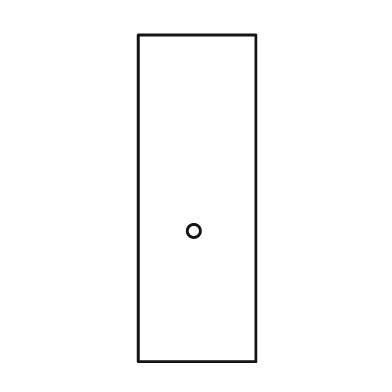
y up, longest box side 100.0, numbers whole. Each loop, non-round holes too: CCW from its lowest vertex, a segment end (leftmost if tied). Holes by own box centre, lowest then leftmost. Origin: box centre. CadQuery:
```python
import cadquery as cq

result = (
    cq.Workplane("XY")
    .moveTo(-18.0, -50.0)
    .lineTo(18.0, -50.0)
    .lineTo(18.0, 50.0)
    .lineTo(-18.0, 50.0)
    .close()
    .moveTo(-1.0, -10.0)
    .circle(2.0)
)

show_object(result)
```